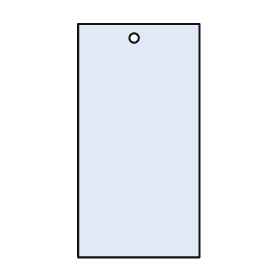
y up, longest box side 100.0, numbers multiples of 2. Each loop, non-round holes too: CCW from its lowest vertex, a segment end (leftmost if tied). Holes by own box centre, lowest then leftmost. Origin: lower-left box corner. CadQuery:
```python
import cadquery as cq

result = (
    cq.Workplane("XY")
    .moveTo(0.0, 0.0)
    .lineTo(52.0, 0.0)
    .lineTo(52.0, 100.0)
    .lineTo(0.0, 100.0)
    .close()
    .moveTo(24.0, 94.0)
    .circle(2.0)
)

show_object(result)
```